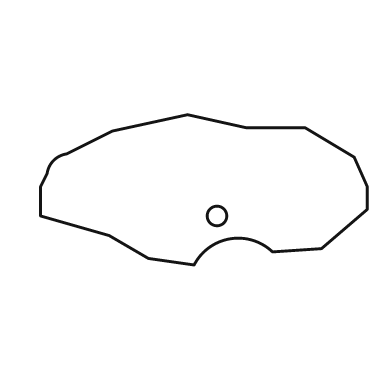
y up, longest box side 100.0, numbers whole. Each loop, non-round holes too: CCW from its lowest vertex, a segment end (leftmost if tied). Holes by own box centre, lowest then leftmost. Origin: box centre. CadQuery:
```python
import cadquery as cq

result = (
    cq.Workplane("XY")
    .moveTo(-3.0, -23.0)
    .threePointArc((8.0, -15.0), (21.0, -19.0))
    .lineTo(36.0, -18.0)
    .lineTo(50.0, -6.0)
    .lineTo(50.0, 1.0)
    .lineTo(46.0, 10.0)
    .lineTo(31.0, 19.0)
    .lineTo(13.0, 19.0)
    .lineTo(-5.0, 23.0)
    .lineTo(-28.0, 18.0)
    .lineTo(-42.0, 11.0)
    .threePointArc((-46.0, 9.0), (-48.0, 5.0))
    .lineTo(-50.0, 1.0)
    .lineTo(-50.0, -8.0)
    .lineTo(-29.0, -14.0)
    .lineTo(-17.0, -21.0)
    .close()
    .moveTo(4.0, -8.0)
    .circle(3.0)
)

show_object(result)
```